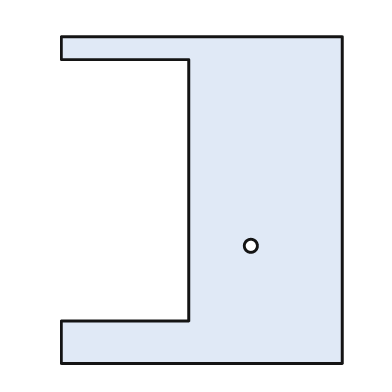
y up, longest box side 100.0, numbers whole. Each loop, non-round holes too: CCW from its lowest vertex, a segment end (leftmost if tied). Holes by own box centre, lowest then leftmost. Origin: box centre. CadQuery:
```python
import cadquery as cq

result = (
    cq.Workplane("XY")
    .moveTo(-43.0, -50.0)
    .lineTo(43.0, -50.0)
    .lineTo(43.0, 50.0)
    .lineTo(-43.0, 50.0)
    .lineTo(-43.0, 43.0)
    .lineTo(-4.0, 43.0)
    .lineTo(-4.0, -37.0)
    .lineTo(-43.0, -37.0)
    .close()
    .moveTo(15.0, -14.0)
    .circle(2.0)
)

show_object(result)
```